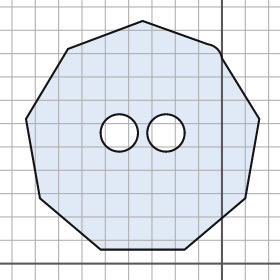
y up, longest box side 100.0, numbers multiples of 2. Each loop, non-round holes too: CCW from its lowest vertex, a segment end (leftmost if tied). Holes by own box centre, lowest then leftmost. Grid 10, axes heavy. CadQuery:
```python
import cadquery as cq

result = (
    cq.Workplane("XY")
    .moveTo(-52.0, 6.0)
    .lineTo(-16.0, 6.0)
    .lineTo(10.0, 28.0)
    .lineTo(16.0, 62.0)
    .lineTo(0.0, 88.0)
    .threePointArc((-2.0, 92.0), (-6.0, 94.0))
    .lineTo(-34.0, 104.0)
    .lineTo(-66.0, 92.0)
    .lineTo(-84.0, 62.0)
    .lineTo(-78.0, 28.0)
    .close()
    .moveTo(-44.0, 56.0)
    .circle(8.0)
    .moveTo(-24.0, 56.0)
    .circle(8.0)
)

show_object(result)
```